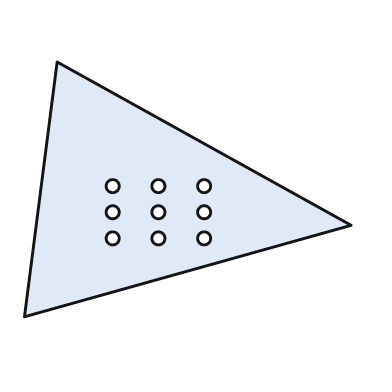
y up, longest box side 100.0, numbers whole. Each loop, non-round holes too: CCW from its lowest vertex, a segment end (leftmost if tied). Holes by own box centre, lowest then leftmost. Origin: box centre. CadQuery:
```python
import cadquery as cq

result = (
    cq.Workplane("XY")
    .moveTo(-50.0, -39.0)
    .lineTo(50.0, -11.0)
    .lineTo(-40.0, 39.0)
    .close()
    .moveTo(-23.0, -15.0)
    .circle(2.0)
    .moveTo(-9.0, -15.0)
    .circle(2.0)
    .moveTo(5.0, -15.0)
    .circle(2.0)
    .moveTo(-23.0, -7.0)
    .circle(2.0)
    .moveTo(-9.0, -7.0)
    .circle(2.0)
    .moveTo(5.0, -7.0)
    .circle(2.0)
    .moveTo(-23.0, 1.0)
    .circle(2.0)
    .moveTo(-9.0, 1.0)
    .circle(2.0)
    .moveTo(5.0, 1.0)
    .circle(2.0)
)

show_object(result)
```